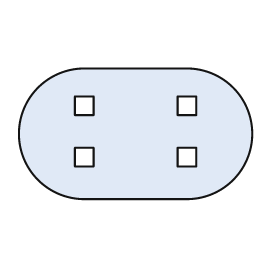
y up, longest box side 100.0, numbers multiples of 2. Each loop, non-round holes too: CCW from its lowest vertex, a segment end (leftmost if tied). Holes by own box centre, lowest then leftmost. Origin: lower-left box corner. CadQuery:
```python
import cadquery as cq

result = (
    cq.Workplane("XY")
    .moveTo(28.0, 0.0)
    .lineTo(72.0, 0.0)
    .threePointArc((100.0, 28.0), (72.0, 56.0))
    .lineTo(28.0, 56.0)
    .threePointArc((0.0, 28.0), (28.0, 0.0))
    .close()
    .moveTo(24.0, 14.0)
    .lineTo(32.0, 14.0)
    .lineTo(32.0, 22.0)
    .lineTo(24.0, 22.0)
    .close()
    .moveTo(68.0, 14.0)
    .lineTo(76.0, 14.0)
    .lineTo(76.0, 22.0)
    .lineTo(68.0, 22.0)
    .close()
    .moveTo(24.0, 36.0)
    .lineTo(32.0, 36.0)
    .lineTo(32.0, 44.0)
    .lineTo(24.0, 44.0)
    .close()
    .moveTo(68.0, 36.0)
    .lineTo(76.0, 36.0)
    .lineTo(76.0, 44.0)
    .lineTo(68.0, 44.0)
    .close()
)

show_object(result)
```